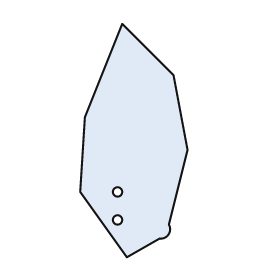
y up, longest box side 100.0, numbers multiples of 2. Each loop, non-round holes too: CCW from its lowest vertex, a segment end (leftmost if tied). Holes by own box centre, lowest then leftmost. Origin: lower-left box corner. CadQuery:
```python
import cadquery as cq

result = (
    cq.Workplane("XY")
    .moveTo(20.0, 0.0)
    .lineTo(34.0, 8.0)
    .threePointArc((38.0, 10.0), (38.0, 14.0))
    .lineTo(46.0, 46.0)
    .lineTo(40.0, 78.0)
    .lineTo(18.0, 100.0)
    .lineTo(2.0, 60.0)
    .lineTo(0.0, 28.0)
    .close()
    .moveTo(16.0, 16.0)
    .circle(2.0)
    .moveTo(16.0, 28.0)
    .circle(2.0)
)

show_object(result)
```